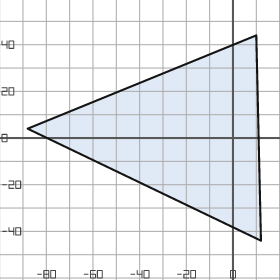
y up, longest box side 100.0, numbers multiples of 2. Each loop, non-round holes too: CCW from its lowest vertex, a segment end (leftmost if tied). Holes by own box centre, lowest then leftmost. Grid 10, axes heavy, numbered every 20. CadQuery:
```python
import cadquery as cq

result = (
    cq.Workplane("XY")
    .moveTo(12.0, -44.0)
    .lineTo(10.0, 44.0)
    .lineTo(-88.0, 4.0)
    .close()
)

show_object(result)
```